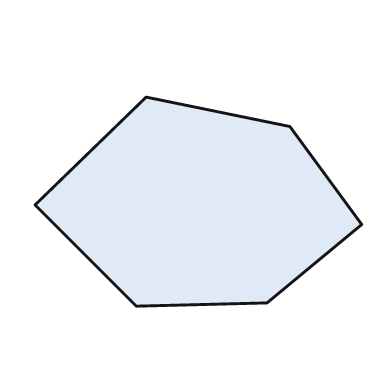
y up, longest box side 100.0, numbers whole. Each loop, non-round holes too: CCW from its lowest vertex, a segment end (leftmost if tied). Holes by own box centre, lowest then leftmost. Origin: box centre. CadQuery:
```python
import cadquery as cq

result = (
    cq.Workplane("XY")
    .moveTo(-19.0, -32.0)
    .lineTo(21.0, -31.0)
    .lineTo(50.0, -7.0)
    .lineTo(28.0, 23.0)
    .lineTo(-16.0, 32.0)
    .lineTo(-50.0, -1.0)
    .close()
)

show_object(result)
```